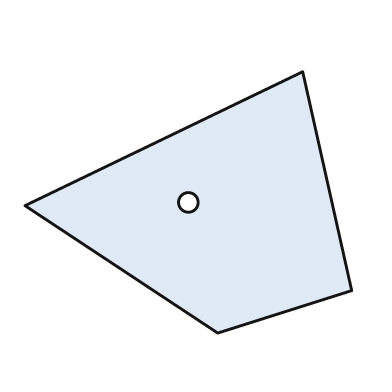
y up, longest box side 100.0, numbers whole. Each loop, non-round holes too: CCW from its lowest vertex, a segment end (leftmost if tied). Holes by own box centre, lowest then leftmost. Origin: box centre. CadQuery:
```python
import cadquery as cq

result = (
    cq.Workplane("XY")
    .moveTo(9.0, -40.0)
    .lineTo(50.0, -27.0)
    .lineTo(35.0, 40.0)
    .lineTo(-50.0, -1.0)
    .close()
    .moveTo(0.0, 0.0)
    .circle(3.0)
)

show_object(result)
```